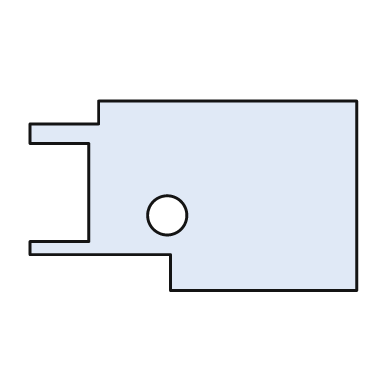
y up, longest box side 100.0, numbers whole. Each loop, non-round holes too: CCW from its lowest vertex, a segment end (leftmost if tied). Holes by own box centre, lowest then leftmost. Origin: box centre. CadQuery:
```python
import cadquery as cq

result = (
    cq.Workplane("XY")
    .moveTo(-7.0, -29.0)
    .lineTo(50.0, -29.0)
    .lineTo(50.0, 29.0)
    .lineTo(-29.0, 29.0)
    .lineTo(-29.0, 22.0)
    .lineTo(-50.0, 22.0)
    .lineTo(-50.0, 16.0)
    .lineTo(-32.0, 16.0)
    .lineTo(-32.0, -14.0)
    .lineTo(-50.0, -14.0)
    .lineTo(-50.0, -18.0)
    .lineTo(-7.0, -18.0)
    .close()
    .moveTo(-8.0, -6.0)
    .circle(6.0)
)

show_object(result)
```